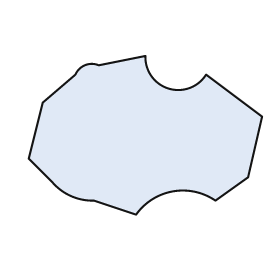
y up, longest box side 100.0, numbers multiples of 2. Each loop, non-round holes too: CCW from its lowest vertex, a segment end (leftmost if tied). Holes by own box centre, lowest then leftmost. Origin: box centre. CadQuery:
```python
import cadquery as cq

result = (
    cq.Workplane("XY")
    .moveTo(-4.0, -34.0)
    .threePointArc((12.0, -24.0), (30.0, -28.0))
    .lineTo(44.0, -18.0)
    .lineTo(50.0, 8.0)
    .lineTo(26.0, 26.0)
    .threePointArc((10.0, 20.0), (0.0, 34.0))
    .lineTo(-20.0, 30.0)
    .threePointArc((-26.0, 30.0), (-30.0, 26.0))
    .lineTo(-44.0, 14.0)
    .lineTo(-50.0, -10.0)
    .lineTo(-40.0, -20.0)
    .threePointArc((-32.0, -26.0), (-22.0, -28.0))
    .close()
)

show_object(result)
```